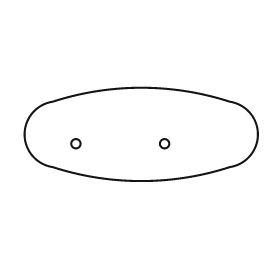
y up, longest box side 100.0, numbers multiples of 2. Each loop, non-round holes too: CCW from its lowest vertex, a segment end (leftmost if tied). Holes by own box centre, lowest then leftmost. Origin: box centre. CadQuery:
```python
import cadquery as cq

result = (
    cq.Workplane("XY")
    .moveTo(-38.0, -14.0)
    .threePointArc((0.0, -20.0), (38.0, -14.0))
    .threePointArc((50.0, 0.0), (38.0, 14.0))
    .threePointArc((0.0, 20.0), (-38.0, 14.0))
    .threePointArc((-50.0, 0.0), (-38.0, -14.0))
    .close()
    .moveTo(-28.0, -4.0)
    .circle(2.0)
    .moveTo(10.0, -4.0)
    .circle(2.0)
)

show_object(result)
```